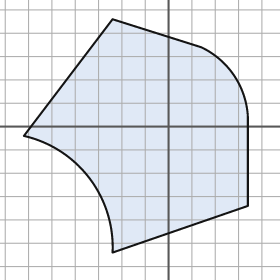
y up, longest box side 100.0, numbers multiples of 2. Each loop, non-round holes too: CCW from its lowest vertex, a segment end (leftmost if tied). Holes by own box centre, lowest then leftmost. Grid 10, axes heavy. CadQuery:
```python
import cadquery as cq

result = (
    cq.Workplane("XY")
    .moveTo(-24.0, -54.0)
    .lineTo(34.0, -34.0)
    .lineTo(34.0, 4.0)
    .threePointArc((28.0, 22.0), (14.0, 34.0))
    .lineTo(-24.0, 46.0)
    .lineTo(-62.0, -4.0)
    .threePointArc((-34.0, -22.0), (-24.0, -54.0))
    .close()
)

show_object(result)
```